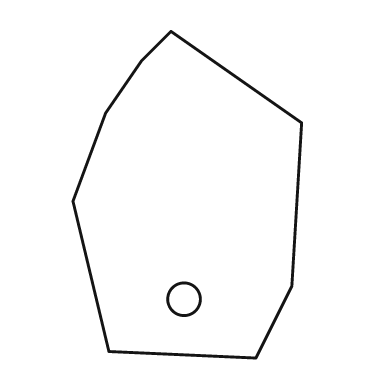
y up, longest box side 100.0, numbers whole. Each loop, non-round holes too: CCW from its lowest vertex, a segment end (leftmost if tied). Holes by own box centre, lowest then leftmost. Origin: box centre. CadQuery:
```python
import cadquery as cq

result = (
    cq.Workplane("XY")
    .moveTo(21.0, -50.0)
    .lineTo(32.0, -28.0)
    .lineTo(35.0, 22.0)
    .lineTo(-5.0, 50.0)
    .lineTo(-14.0, 41.0)
    .lineTo(-25.0, 25.0)
    .lineTo(-35.0, -2.0)
    .lineTo(-24.0, -48.0)
    .close()
    .moveTo(-1.0, -32.0)
    .circle(5.0)
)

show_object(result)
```